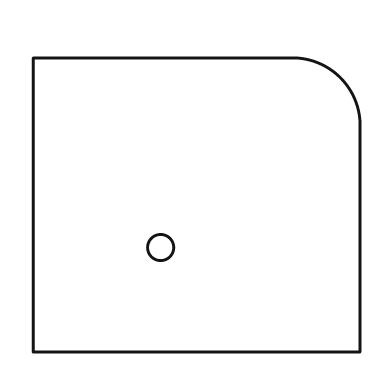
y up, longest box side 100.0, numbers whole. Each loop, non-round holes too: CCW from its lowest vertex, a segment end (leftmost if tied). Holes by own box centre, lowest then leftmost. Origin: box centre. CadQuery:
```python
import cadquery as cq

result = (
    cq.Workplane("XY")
    .moveTo(-50.0, -45.0)
    .lineTo(50.0, -45.0)
    .lineTo(50.0, 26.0)
    .threePointArc((44.0, 39.0), (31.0, 45.0))
    .lineTo(-50.0, 45.0)
    .close()
    .moveTo(-11.0, -13.0)
    .circle(4.0)
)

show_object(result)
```